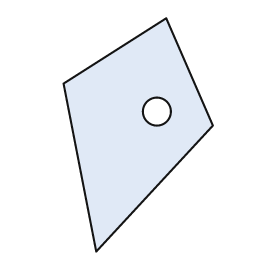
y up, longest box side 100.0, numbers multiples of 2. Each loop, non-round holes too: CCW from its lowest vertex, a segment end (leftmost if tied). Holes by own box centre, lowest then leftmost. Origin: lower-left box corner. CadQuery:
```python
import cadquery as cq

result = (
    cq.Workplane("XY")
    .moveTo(14.0, 0.0)
    .lineTo(64.0, 54.0)
    .lineTo(44.0, 100.0)
    .lineTo(0.0, 72.0)
    .close()
    .moveTo(40.0, 60.0)
    .circle(6.0)
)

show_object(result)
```